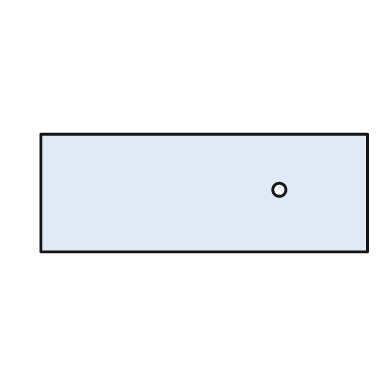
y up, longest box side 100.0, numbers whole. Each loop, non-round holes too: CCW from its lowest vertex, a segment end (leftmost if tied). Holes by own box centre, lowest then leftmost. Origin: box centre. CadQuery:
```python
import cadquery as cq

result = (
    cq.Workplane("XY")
    .moveTo(-50.0, -18.0)
    .lineTo(50.0, -18.0)
    .lineTo(50.0, 18.0)
    .lineTo(-50.0, 18.0)
    .close()
    .moveTo(23.0, 1.0)
    .circle(2.0)
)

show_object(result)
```